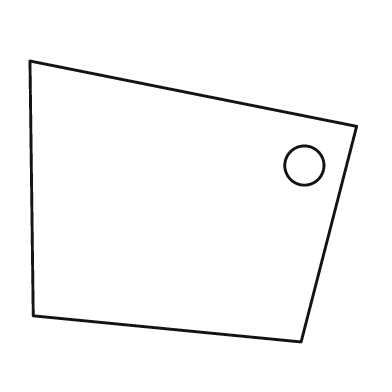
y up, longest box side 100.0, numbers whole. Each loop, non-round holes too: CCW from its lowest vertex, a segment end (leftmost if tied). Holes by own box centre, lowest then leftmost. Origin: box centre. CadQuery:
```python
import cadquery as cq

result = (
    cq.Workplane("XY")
    .moveTo(33.0, -43.0)
    .lineTo(50.0, 23.0)
    .lineTo(-50.0, 43.0)
    .lineTo(-49.0, -35.0)
    .close()
    .moveTo(34.0, 11.0)
    .circle(6.0)
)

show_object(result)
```